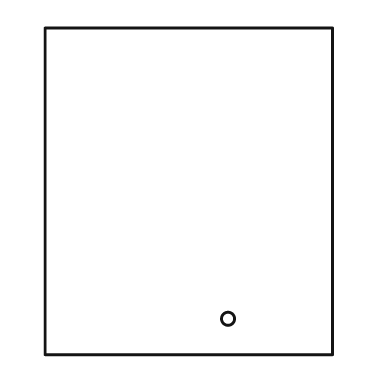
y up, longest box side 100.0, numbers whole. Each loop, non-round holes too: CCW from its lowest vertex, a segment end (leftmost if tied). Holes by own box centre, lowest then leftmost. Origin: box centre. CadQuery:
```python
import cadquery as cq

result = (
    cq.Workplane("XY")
    .moveTo(-44.0, -50.0)
    .lineTo(44.0, -50.0)
    .lineTo(44.0, 50.0)
    .lineTo(-44.0, 50.0)
    .close()
    .moveTo(12.0, -39.0)
    .circle(2.0)
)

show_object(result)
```